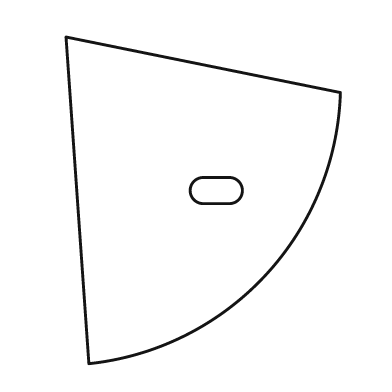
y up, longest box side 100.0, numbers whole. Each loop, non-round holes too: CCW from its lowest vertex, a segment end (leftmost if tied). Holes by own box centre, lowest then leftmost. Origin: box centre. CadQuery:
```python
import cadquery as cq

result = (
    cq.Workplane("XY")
    .moveTo(-35.0, -50.0)
    .threePointArc((19.0, -23.0), (42.0, 33.0))
    .lineTo(-42.0, 50.0)
    .close()
    .moveTo(0.0, -1.0)
    .lineTo(8.0, -1.0)
    .threePointArc((12.0, 3.0), (8.0, 7.0))
    .lineTo(0.0, 7.0)
    .threePointArc((-4.0, 3.0), (0.0, -1.0))
    .close()
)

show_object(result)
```